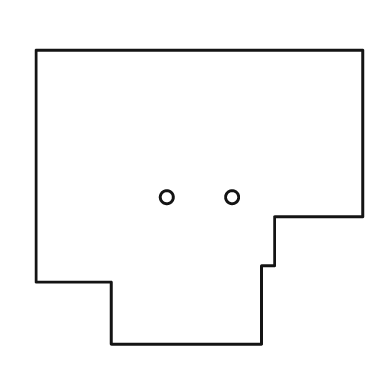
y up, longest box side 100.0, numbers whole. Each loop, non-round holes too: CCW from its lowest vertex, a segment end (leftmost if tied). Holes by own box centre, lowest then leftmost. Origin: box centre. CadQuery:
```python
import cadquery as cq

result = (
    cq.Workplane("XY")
    .moveTo(-27.0, -45.0)
    .lineTo(19.0, -45.0)
    .lineTo(19.0, -21.0)
    .lineTo(23.0, -21.0)
    .lineTo(23.0, -6.0)
    .lineTo(50.0, -6.0)
    .lineTo(50.0, 45.0)
    .lineTo(-50.0, 45.0)
    .lineTo(-50.0, -26.0)
    .lineTo(-27.0, -26.0)
    .close()
    .moveTo(-10.0, 0.0)
    .circle(2.0)
    .moveTo(10.0, 0.0)
    .circle(2.0)
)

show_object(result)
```